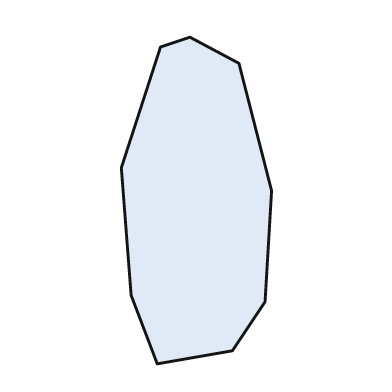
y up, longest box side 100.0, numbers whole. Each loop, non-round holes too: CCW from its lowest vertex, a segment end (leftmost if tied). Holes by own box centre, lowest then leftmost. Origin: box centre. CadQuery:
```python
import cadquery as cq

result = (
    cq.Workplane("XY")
    .moveTo(-12.0, -50.0)
    .lineTo(11.0, -46.0)
    .lineTo(21.0, -31.0)
    .lineTo(23.0, 3.0)
    .lineTo(13.0, 42.0)
    .lineTo(-2.0, 50.0)
    .lineTo(-11.0, 47.0)
    .lineTo(-23.0, 10.0)
    .lineTo(-20.0, -29.0)
    .close()
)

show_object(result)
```